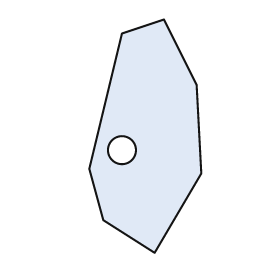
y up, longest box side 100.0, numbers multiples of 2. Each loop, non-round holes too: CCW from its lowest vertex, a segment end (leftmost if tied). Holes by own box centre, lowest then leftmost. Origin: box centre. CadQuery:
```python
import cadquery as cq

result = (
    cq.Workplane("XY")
    .moveTo(4.0, -50.0)
    .lineTo(24.0, -16.0)
    .lineTo(22.0, 22.0)
    .lineTo(8.0, 50.0)
    .lineTo(-10.0, 44.0)
    .lineTo(-24.0, -14.0)
    .lineTo(-18.0, -36.0)
    .close()
    .moveTo(-10.0, -6.0)
    .circle(6.0)
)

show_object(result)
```